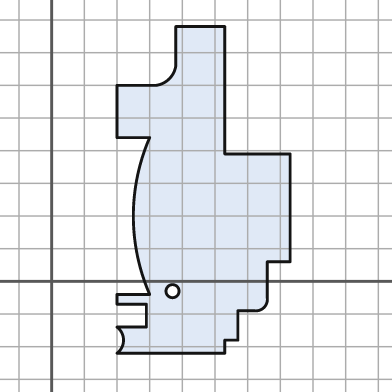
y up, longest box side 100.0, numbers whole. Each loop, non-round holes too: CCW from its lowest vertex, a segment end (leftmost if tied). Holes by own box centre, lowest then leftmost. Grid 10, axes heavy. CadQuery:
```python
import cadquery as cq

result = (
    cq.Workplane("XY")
    .moveTo(20.0, -22.0)
    .lineTo(53.0, -22.0)
    .lineTo(53.0, -18.0)
    .lineTo(57.0, -18.0)
    .lineTo(57.0, -9.0)
    .lineTo(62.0, -9.0)
    .threePointArc((65.0, -8.0), (66.0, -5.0))
    .lineTo(66.0, 6.0)
    .lineTo(73.0, 6.0)
    .lineTo(73.0, 39.0)
    .lineTo(53.0, 39.0)
    .lineTo(53.0, 78.0)
    .lineTo(38.0, 78.0)
    .lineTo(38.0, 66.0)
    .threePointArc((36.0, 62.0), (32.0, 60.0))
    .lineTo(20.0, 60.0)
    .lineTo(20.0, 44.0)
    .lineTo(30.0, 44.0)
    .threePointArc((25.0, 20.0), (30.0, -4.0))
    .lineTo(20.0, -4.0)
    .lineTo(20.0, -7.0)
    .lineTo(29.0, -7.0)
    .lineTo(29.0, -14.0)
    .lineTo(20.0, -14.0)
    .threePointArc((22.0, -18.0), (20.0, -22.0))
    .close()
    .moveTo(37.0, -3.0)
    .circle(2.0)
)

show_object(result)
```